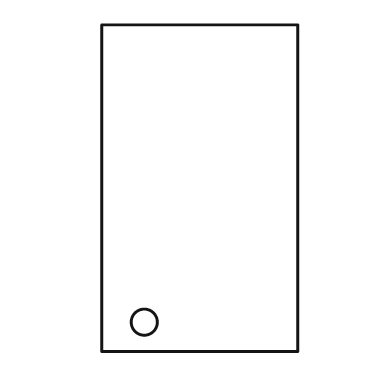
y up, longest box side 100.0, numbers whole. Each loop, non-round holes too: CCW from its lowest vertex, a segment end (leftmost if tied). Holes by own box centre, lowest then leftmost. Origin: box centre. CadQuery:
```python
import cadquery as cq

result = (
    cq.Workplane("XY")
    .moveTo(-30.0, -50.0)
    .lineTo(30.0, -50.0)
    .lineTo(30.0, 50.0)
    .lineTo(-30.0, 50.0)
    .close()
    .moveTo(-17.0, -41.0)
    .circle(4.0)
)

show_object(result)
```